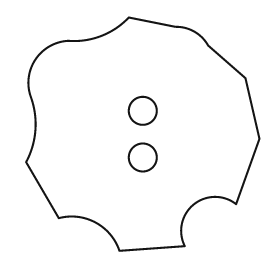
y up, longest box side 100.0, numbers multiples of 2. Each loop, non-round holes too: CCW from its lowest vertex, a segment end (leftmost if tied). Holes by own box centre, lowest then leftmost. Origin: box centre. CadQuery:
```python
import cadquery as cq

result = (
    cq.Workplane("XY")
    .moveTo(-10.0, -50.0)
    .lineTo(18.0, -48.0)
    .threePointArc((22.0, -30.0), (40.0, -30.0))
    .lineTo(50.0, -2.0)
    .lineTo(44.0, 24.0)
    .lineTo(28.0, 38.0)
    .threePointArc((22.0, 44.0), (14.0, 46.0))
    .lineTo(-6.0, 50.0)
    .threePointArc((-18.0, 42.0), (-32.0, 40.0))
    .threePointArc((-46.0, 32.0), (-48.0, 16.0))
    .threePointArc((-46.0, 2.0), (-50.0, -12.0))
    .lineTo(-36.0, -36.0)
    .threePointArc((-20.0, -38.0), (-10.0, -50.0))
    .close()
    .moveTo(0.0, -10.0)
    .circle(6.0)
    .moveTo(0.0, 10.0)
    .circle(6.0)
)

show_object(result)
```